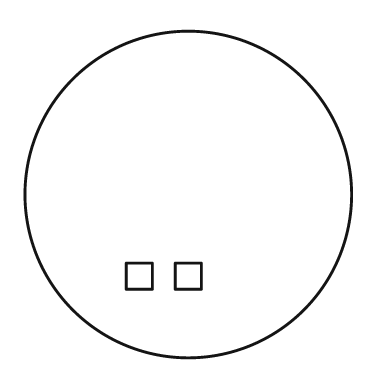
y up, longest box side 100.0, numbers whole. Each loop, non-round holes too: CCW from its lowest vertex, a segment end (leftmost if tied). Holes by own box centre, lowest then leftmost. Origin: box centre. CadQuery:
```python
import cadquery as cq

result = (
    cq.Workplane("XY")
    .moveTo(0.0, 0.0)
    .circle(50.0)
    .moveTo(-19.0, -29.0)
    .lineTo(-11.0, -29.0)
    .lineTo(-11.0, -21.0)
    .lineTo(-19.0, -21.0)
    .close()
    .moveTo(-4.0, -29.0)
    .lineTo(4.0, -29.0)
    .lineTo(4.0, -21.0)
    .lineTo(-4.0, -21.0)
    .close()
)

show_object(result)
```